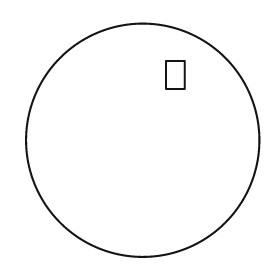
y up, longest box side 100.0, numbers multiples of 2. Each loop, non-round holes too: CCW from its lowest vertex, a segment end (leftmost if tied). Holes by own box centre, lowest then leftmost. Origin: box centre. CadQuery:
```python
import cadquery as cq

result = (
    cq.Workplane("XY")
    .moveTo(0.0, 0.0)
    .circle(50.0)
    .moveTo(10.0, 22.0)
    .lineTo(18.0, 22.0)
    .lineTo(18.0, 34.0)
    .lineTo(10.0, 34.0)
    .close()
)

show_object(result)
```